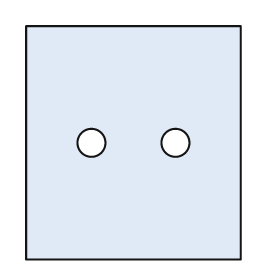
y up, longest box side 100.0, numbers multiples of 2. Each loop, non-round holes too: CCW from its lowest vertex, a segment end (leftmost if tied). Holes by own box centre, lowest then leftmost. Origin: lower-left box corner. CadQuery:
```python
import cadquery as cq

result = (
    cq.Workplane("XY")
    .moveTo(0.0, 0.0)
    .lineTo(92.0, 0.0)
    .lineTo(92.0, 100.0)
    .lineTo(0.0, 100.0)
    .close()
    .moveTo(28.0, 50.0)
    .circle(6.0)
    .moveTo(64.0, 50.0)
    .circle(6.0)
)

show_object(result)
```